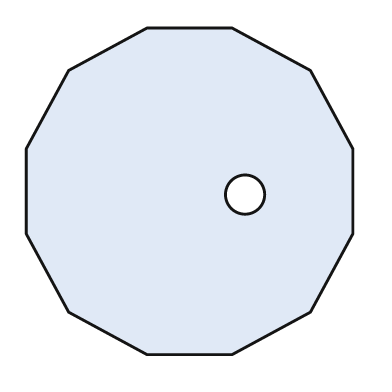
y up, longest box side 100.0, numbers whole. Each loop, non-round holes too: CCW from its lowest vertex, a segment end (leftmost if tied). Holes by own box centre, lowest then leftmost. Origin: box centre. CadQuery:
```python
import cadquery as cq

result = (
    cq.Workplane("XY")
    .moveTo(-13.0, -50.0)
    .lineTo(13.0, -50.0)
    .lineTo(37.0, -37.0)
    .lineTo(50.0, -13.0)
    .lineTo(50.0, 13.0)
    .lineTo(37.0, 37.0)
    .lineTo(13.0, 50.0)
    .lineTo(-13.0, 50.0)
    .lineTo(-37.0, 37.0)
    .lineTo(-50.0, 13.0)
    .lineTo(-50.0, -13.0)
    .lineTo(-37.0, -37.0)
    .close()
    .moveTo(17.0, -1.0)
    .circle(6.0)
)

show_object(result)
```